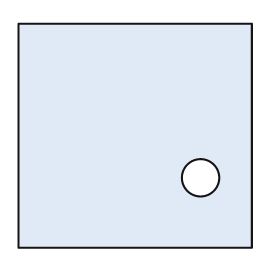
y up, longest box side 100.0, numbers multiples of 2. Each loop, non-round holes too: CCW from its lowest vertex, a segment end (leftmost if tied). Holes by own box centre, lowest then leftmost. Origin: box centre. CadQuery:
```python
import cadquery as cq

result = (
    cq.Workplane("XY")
    .moveTo(-50.0, -48.0)
    .lineTo(50.0, -48.0)
    .lineTo(50.0, 48.0)
    .lineTo(-50.0, 48.0)
    .close()
    .moveTo(28.0, -18.0)
    .circle(8.0)
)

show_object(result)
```